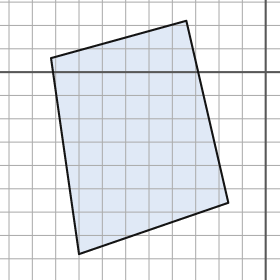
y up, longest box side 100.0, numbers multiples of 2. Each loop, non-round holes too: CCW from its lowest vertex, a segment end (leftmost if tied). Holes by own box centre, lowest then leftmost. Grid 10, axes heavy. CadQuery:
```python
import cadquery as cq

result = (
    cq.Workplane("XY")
    .moveTo(-80.0, -78.0)
    .lineTo(-16.0, -56.0)
    .lineTo(-34.0, 22.0)
    .lineTo(-92.0, 6.0)
    .close()
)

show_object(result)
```